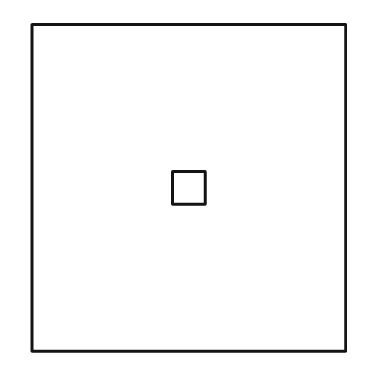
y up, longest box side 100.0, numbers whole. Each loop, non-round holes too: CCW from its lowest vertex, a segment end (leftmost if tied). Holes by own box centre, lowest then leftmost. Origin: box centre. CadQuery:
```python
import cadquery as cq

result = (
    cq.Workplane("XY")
    .moveTo(-48.0, -50.0)
    .lineTo(48.0, -50.0)
    .lineTo(48.0, 50.0)
    .lineTo(-48.0, 50.0)
    .close()
    .moveTo(-5.0, -5.0)
    .lineTo(5.0, -5.0)
    .lineTo(5.0, 5.0)
    .lineTo(-5.0, 5.0)
    .close()
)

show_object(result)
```